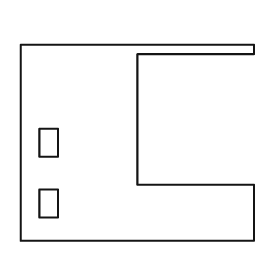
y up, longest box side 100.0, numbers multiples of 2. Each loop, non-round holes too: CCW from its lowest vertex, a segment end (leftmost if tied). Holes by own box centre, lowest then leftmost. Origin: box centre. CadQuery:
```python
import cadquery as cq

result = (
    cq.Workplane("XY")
    .moveTo(-50.0, -42.0)
    .lineTo(50.0, -42.0)
    .lineTo(50.0, -18.0)
    .lineTo(0.0, -18.0)
    .lineTo(0.0, 38.0)
    .lineTo(50.0, 38.0)
    .lineTo(50.0, 42.0)
    .lineTo(-50.0, 42.0)
    .close()
    .moveTo(-42.0, -32.0)
    .lineTo(-34.0, -32.0)
    .lineTo(-34.0, -20.0)
    .lineTo(-42.0, -20.0)
    .close()
    .moveTo(-42.0, -6.0)
    .lineTo(-34.0, -6.0)
    .lineTo(-34.0, 6.0)
    .lineTo(-42.0, 6.0)
    .close()
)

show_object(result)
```